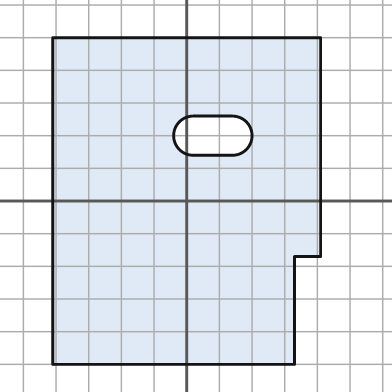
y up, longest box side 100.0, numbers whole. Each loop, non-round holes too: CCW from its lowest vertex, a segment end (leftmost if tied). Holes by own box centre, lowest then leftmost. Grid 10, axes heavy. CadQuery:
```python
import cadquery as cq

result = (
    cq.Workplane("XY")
    .moveTo(-41.0, -50.0)
    .lineTo(33.0, -50.0)
    .lineTo(33.0, -17.0)
    .lineTo(41.0, -17.0)
    .lineTo(41.0, 50.0)
    .lineTo(-41.0, 50.0)
    .close()
    .moveTo(2.0, 14.0)
    .lineTo(14.0, 14.0)
    .threePointArc((20.0, 20.0), (14.0, 26.0))
    .lineTo(2.0, 26.0)
    .threePointArc((-4.0, 20.0), (2.0, 14.0))
    .close()
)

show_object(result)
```